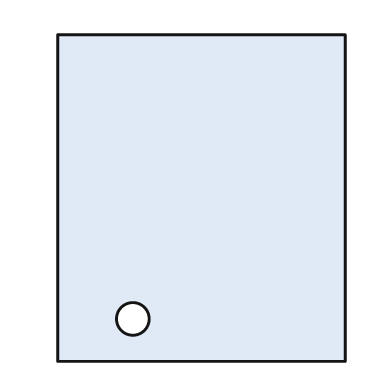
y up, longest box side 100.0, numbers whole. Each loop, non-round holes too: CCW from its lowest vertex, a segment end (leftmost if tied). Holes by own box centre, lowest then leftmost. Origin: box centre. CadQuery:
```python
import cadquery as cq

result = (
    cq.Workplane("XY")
    .moveTo(-44.0, -50.0)
    .lineTo(44.0, -50.0)
    .lineTo(44.0, 50.0)
    .lineTo(-44.0, 50.0)
    .close()
    .moveTo(-21.0, -37.0)
    .circle(5.0)
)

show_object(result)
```